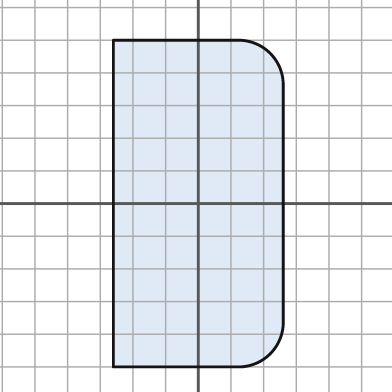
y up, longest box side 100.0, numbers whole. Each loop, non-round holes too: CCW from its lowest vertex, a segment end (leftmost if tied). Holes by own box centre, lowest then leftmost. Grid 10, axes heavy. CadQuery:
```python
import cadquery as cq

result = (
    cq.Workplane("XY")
    .moveTo(-26.0, -50.0)
    .lineTo(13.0, -50.0)
    .threePointArc((22.0, -46.0), (26.0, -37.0))
    .lineTo(26.0, 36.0)
    .threePointArc((22.0, 46.0), (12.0, 50.0))
    .lineTo(-26.0, 50.0)
    .close()
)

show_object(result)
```